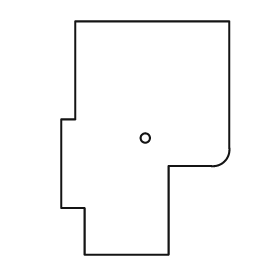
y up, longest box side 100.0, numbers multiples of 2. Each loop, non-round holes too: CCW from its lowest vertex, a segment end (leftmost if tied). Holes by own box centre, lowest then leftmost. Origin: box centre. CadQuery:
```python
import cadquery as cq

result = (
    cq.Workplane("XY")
    .moveTo(-26.0, -50.0)
    .lineTo(10.0, -50.0)
    .lineTo(10.0, -12.0)
    .lineTo(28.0, -12.0)
    .threePointArc((34.0, -10.0), (36.0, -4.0))
    .lineTo(36.0, 50.0)
    .lineTo(-30.0, 50.0)
    .lineTo(-30.0, 8.0)
    .lineTo(-36.0, 8.0)
    .lineTo(-36.0, -30.0)
    .lineTo(-26.0, -30.0)
    .close()
    .moveTo(0.0, 0.0)
    .circle(2.0)
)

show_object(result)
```